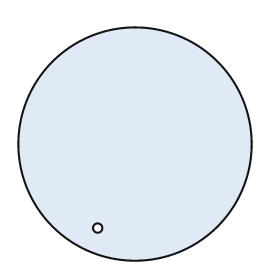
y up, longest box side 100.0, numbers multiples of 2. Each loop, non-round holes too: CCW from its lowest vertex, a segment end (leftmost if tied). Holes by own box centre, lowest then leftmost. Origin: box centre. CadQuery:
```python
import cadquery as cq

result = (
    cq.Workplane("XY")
    .moveTo(0.0, 0.0)
    .circle(50.0)
    .moveTo(-16.0, -36.0)
    .circle(2.0)
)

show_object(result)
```